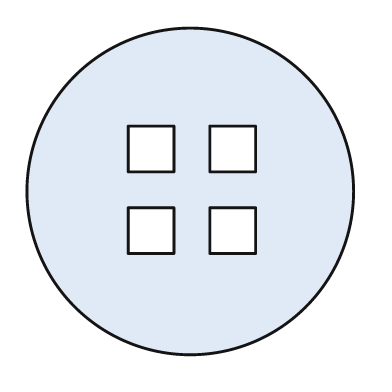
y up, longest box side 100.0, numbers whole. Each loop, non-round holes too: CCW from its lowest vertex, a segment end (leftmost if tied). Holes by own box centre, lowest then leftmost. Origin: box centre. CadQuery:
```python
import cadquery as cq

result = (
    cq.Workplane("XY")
    .moveTo(0.0, 0.0)
    .circle(50.0)
    .moveTo(-19.0, -19.0)
    .lineTo(-5.0, -19.0)
    .lineTo(-5.0, -5.0)
    .lineTo(-19.0, -5.0)
    .close()
    .moveTo(6.0, -19.0)
    .lineTo(20.0, -19.0)
    .lineTo(20.0, -5.0)
    .lineTo(6.0, -5.0)
    .close()
    .moveTo(-19.0, 6.0)
    .lineTo(-5.0, 6.0)
    .lineTo(-5.0, 20.0)
    .lineTo(-19.0, 20.0)
    .close()
    .moveTo(6.0, 6.0)
    .lineTo(20.0, 6.0)
    .lineTo(20.0, 20.0)
    .lineTo(6.0, 20.0)
    .close()
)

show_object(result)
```